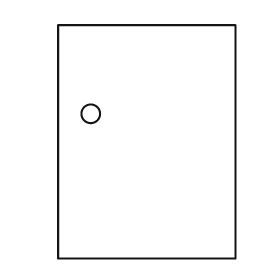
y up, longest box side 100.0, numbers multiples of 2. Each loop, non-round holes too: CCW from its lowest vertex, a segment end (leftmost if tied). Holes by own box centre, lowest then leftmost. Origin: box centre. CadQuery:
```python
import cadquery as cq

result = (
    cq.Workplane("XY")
    .moveTo(-38.0, -50.0)
    .lineTo(38.0, -50.0)
    .lineTo(38.0, 50.0)
    .lineTo(-38.0, 50.0)
    .close()
    .moveTo(-24.0, 12.0)
    .circle(4.0)
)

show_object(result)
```